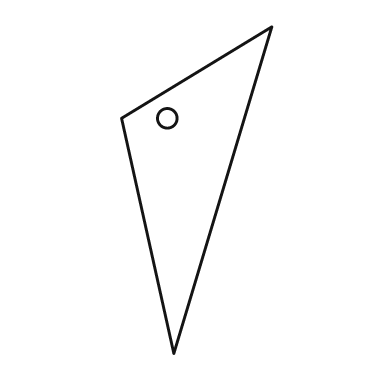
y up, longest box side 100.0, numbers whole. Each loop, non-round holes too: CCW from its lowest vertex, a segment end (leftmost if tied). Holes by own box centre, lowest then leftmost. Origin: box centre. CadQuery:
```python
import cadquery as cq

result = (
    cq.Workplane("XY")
    .moveTo(-7.0, -50.0)
    .lineTo(23.0, 50.0)
    .lineTo(-23.0, 22.0)
    .close()
    .moveTo(-9.0, 22.0)
    .circle(3.0)
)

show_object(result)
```